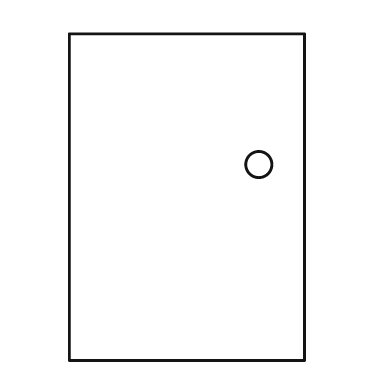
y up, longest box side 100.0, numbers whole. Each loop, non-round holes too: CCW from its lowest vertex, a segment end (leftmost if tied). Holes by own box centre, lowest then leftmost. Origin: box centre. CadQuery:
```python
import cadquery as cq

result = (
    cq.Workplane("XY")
    .moveTo(-36.0, -50.0)
    .lineTo(36.0, -50.0)
    .lineTo(36.0, 50.0)
    .lineTo(-36.0, 50.0)
    .close()
    .moveTo(22.0, 10.0)
    .circle(4.0)
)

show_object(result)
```